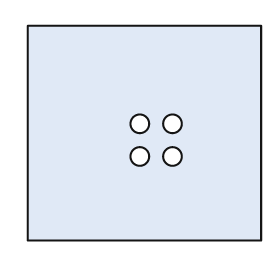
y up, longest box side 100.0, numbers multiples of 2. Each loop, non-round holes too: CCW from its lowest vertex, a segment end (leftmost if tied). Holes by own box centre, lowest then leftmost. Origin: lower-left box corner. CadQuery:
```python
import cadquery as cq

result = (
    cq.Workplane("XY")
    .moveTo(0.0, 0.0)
    .lineTo(100.0, 0.0)
    .lineTo(100.0, 92.0)
    .lineTo(0.0, 92.0)
    .close()
    .moveTo(48.0, 36.0)
    .circle(4.0)
    .moveTo(62.0, 36.0)
    .circle(4.0)
    .moveTo(48.0, 50.0)
    .circle(4.0)
    .moveTo(62.0, 50.0)
    .circle(4.0)
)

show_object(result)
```